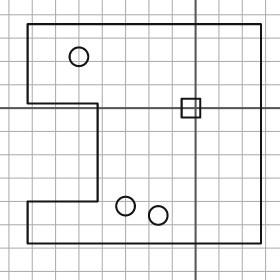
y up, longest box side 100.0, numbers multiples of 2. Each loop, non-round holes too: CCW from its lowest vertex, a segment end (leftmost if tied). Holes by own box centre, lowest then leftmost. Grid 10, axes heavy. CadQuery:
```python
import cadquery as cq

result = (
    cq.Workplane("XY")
    .moveTo(-72.0, -58.0)
    .lineTo(28.0, -58.0)
    .lineTo(28.0, 36.0)
    .lineTo(-72.0, 36.0)
    .lineTo(-72.0, 2.0)
    .lineTo(-42.0, 2.0)
    .lineTo(-42.0, -40.0)
    .lineTo(-72.0, -40.0)
    .close()
    .moveTo(-16.0, -46.0)
    .circle(4.0)
    .moveTo(-30.0, -42.0)
    .circle(4.0)
    .moveTo(-6.0, -4.0)
    .lineTo(2.0, -4.0)
    .lineTo(2.0, 4.0)
    .lineTo(-6.0, 4.0)
    .close()
    .moveTo(-50.0, 22.0)
    .circle(4.0)
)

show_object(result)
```